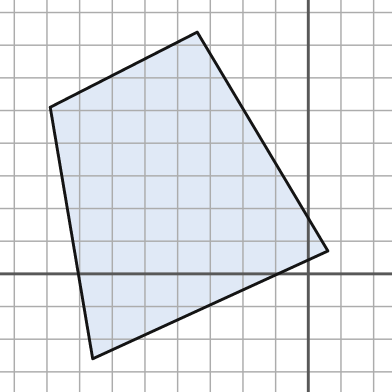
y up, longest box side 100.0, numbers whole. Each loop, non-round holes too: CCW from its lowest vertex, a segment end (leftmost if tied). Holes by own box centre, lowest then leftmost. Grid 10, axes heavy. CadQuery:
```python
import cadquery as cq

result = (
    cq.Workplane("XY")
    .moveTo(-66.0, -26.0)
    .lineTo(6.0, 7.0)
    .lineTo(-34.0, 74.0)
    .lineTo(-79.0, 51.0)
    .close()
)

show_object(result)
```